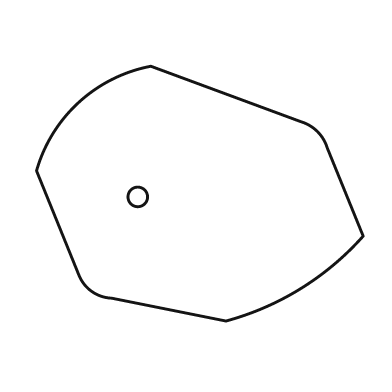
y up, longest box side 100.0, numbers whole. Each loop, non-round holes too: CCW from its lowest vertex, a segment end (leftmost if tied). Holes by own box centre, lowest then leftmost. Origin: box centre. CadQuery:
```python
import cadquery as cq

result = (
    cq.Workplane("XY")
    .moveTo(8.0, -39.0)
    .threePointArc((31.0, -29.0), (50.0, -13.0))
    .lineTo(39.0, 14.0)
    .threePointArc((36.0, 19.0), (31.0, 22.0))
    .lineTo(-15.0, 39.0)
    .threePointArc((-37.0, 28.0), (-50.0, 7.0))
    .lineTo(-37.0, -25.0)
    .threePointArc((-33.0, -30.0), (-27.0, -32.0))
    .close()
    .moveTo(-19.0, -1.0)
    .circle(3.0)
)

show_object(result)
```